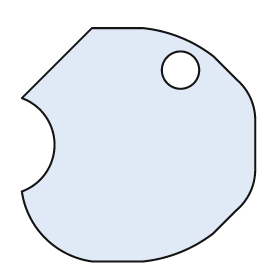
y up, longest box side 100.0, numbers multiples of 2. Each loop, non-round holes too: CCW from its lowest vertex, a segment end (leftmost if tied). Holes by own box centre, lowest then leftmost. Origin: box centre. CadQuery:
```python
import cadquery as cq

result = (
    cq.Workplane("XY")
    .moveTo(-20.0, -50.0)
    .lineTo(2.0, -50.0)
    .threePointArc((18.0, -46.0), (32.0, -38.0))
    .lineTo(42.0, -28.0)
    .threePointArc((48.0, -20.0), (50.0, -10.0))
    .lineTo(50.0, 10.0)
    .threePointArc((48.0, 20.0), (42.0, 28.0))
    .lineTo(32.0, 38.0)
    .threePointArc((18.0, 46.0), (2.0, 50.0))
    .lineTo(-20.0, 50.0)
    .lineTo(-50.0, 20.0)
    .threePointArc((-36.0, 0.0), (-50.0, -20.0))
    .threePointArc((-40.0, -40.0), (-20.0, -50.0))
    .close()
    .moveTo(18.0, 32.0)
    .circle(8.0)
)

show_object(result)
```